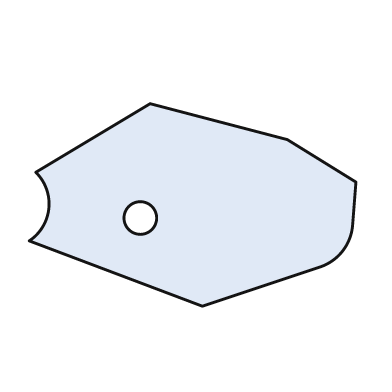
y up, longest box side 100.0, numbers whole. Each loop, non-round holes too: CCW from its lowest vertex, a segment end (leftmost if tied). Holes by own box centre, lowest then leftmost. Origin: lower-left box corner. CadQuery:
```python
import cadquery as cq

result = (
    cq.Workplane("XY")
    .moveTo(53.0, 0.0)
    .lineTo(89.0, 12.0)
    .threePointArc((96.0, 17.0), (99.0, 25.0))
    .lineTo(100.0, 38.0)
    .lineTo(79.0, 51.0)
    .lineTo(37.0, 62.0)
    .lineTo(2.0, 41.0)
    .threePointArc((6.0, 30.0), (0.0, 20.0))
    .close()
    .moveTo(34.0, 27.0)
    .circle(5.0)
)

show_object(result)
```